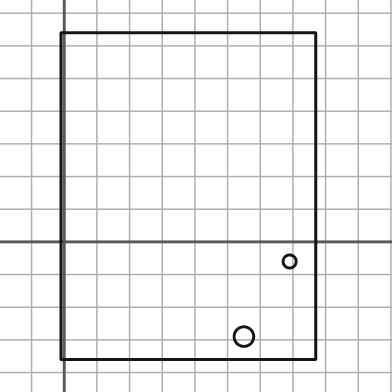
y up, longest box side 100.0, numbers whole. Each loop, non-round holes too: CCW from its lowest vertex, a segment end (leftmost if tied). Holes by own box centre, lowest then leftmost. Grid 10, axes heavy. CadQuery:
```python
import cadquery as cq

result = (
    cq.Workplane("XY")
    .moveTo(-1.0, -36.0)
    .lineTo(77.0, -36.0)
    .lineTo(77.0, 64.0)
    .lineTo(-1.0, 64.0)
    .close()
    .moveTo(55.0, -29.0)
    .circle(3.0)
    .moveTo(69.0, -6.0)
    .circle(2.0)
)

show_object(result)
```